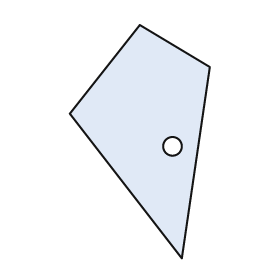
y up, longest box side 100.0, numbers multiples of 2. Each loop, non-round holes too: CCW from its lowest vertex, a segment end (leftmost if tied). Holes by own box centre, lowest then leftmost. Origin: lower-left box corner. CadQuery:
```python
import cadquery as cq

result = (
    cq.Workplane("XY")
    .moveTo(48.0, 0.0)
    .lineTo(60.0, 82.0)
    .lineTo(30.0, 100.0)
    .lineTo(0.0, 62.0)
    .close()
    .moveTo(44.0, 48.0)
    .circle(4.0)
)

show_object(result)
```